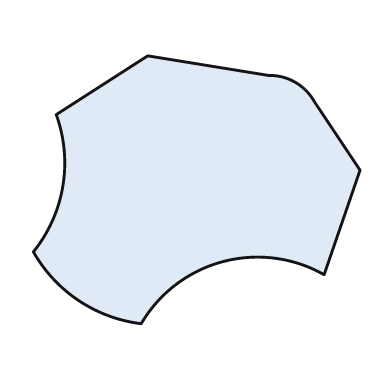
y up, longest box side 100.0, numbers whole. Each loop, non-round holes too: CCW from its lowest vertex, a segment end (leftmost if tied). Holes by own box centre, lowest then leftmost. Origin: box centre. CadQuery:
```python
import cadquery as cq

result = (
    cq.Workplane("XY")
    .moveTo(-17.0, -41.0)
    .threePointArc((8.0, -22.0), (39.0, -26.0))
    .lineTo(50.0, 6.0)
    .lineTo(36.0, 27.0)
    .threePointArc((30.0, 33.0), (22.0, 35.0))
    .lineTo(-15.0, 41.0)
    .lineTo(-43.0, 23.0)
    .threePointArc((-41.0, 1.0), (-50.0, -19.0))
    .threePointArc((-36.0, -34.0), (-17.0, -41.0))
    .close()
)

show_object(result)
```